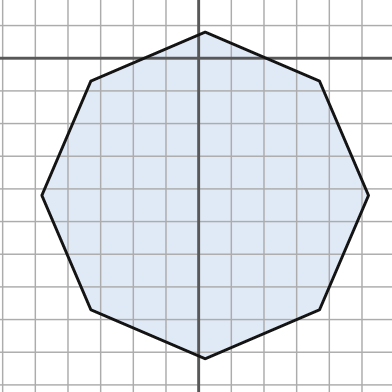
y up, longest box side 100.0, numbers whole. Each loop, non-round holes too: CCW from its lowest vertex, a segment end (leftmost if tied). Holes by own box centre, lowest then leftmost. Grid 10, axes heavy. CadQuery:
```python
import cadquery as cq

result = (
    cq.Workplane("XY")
    .moveTo(2.0, -92.0)
    .lineTo(37.0, -77.0)
    .lineTo(52.0, -42.0)
    .lineTo(37.0, -7.0)
    .lineTo(2.0, 8.0)
    .lineTo(-33.0, -7.0)
    .lineTo(-48.0, -42.0)
    .lineTo(-33.0, -77.0)
    .close()
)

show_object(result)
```